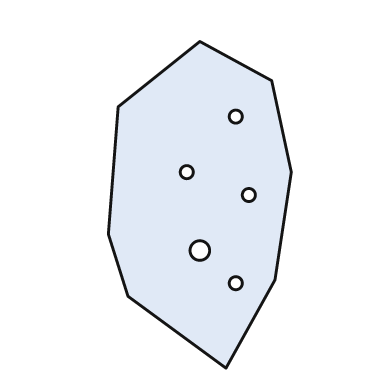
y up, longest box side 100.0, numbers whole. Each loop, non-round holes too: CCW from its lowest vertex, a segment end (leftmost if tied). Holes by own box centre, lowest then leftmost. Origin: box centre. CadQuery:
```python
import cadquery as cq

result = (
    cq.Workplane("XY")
    .moveTo(8.0, -50.0)
    .lineTo(23.0, -23.0)
    .lineTo(28.0, 10.0)
    .lineTo(22.0, 38.0)
    .lineTo(0.0, 50.0)
    .lineTo(-25.0, 30.0)
    .lineTo(-28.0, -9.0)
    .lineTo(-22.0, -28.0)
    .close()
    .moveTo(11.0, -24.0)
    .circle(2.0)
    .moveTo(0.0, -14.0)
    .circle(3.0)
    .moveTo(15.0, 3.0)
    .circle(2.0)
    .moveTo(-4.0, 10.0)
    .circle(2.0)
    .moveTo(11.0, 27.0)
    .circle(2.0)
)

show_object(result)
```